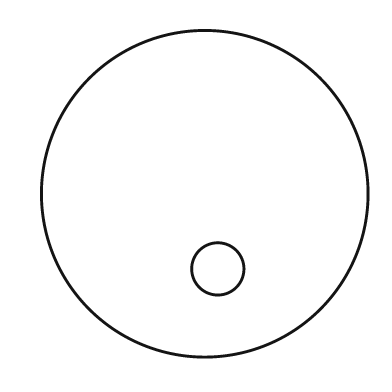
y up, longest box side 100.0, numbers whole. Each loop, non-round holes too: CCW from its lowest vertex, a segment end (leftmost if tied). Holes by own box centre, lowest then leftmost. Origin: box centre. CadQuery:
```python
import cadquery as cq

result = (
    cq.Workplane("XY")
    .moveTo(0.0, 0.0)
    .circle(50.0)
    .moveTo(4.0, -23.0)
    .circle(8.0)
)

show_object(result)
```